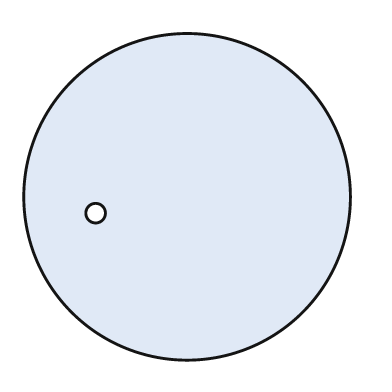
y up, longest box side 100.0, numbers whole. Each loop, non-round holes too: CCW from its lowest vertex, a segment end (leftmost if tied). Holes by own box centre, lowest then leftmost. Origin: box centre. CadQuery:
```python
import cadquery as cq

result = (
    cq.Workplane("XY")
    .moveTo(0.0, 0.0)
    .circle(50.0)
    .moveTo(-28.0, -5.0)
    .circle(3.0)
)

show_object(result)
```